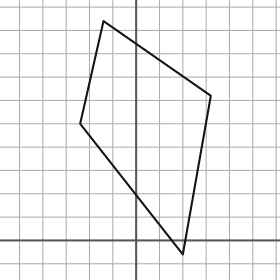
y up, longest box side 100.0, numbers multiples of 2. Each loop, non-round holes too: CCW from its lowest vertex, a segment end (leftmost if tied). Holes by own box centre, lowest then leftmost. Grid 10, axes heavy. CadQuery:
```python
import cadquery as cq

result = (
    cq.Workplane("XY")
    .moveTo(20.0, -6.0)
    .lineTo(32.0, 62.0)
    .lineTo(-14.0, 94.0)
    .lineTo(-24.0, 50.0)
    .close()
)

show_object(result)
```